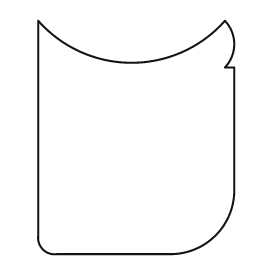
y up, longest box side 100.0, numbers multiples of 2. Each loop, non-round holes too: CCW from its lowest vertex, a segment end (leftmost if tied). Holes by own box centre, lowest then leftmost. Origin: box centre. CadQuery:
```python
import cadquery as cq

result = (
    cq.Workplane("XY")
    .moveTo(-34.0, -50.0)
    .lineTo(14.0, -50.0)
    .threePointArc((34.0, -42.0), (42.0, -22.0))
    .lineTo(42.0, 30.0)
    .lineTo(38.0, 30.0)
    .threePointArc((42.0, 40.0), (38.0, 50.0))
    .threePointArc((-2.0, 32.0), (-42.0, 50.0))
    .lineTo(-42.0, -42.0)
    .threePointArc((-40.0, -48.0), (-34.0, -50.0))
    .close()
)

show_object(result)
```